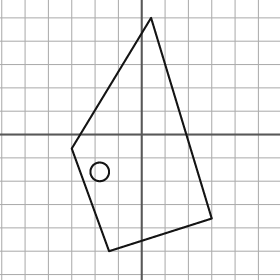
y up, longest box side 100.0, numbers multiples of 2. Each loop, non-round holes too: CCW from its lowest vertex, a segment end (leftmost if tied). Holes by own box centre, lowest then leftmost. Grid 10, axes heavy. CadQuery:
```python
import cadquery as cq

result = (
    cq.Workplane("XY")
    .moveTo(-14.0, -50.0)
    .lineTo(30.0, -36.0)
    .lineTo(4.0, 50.0)
    .lineTo(-30.0, -6.0)
    .close()
    .moveTo(-18.0, -16.0)
    .circle(4.0)
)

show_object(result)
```